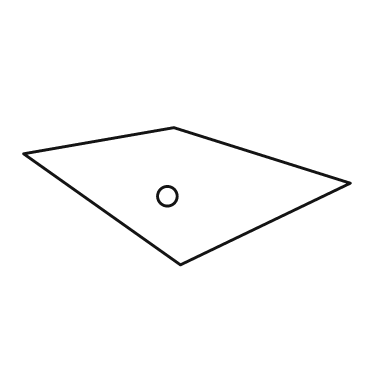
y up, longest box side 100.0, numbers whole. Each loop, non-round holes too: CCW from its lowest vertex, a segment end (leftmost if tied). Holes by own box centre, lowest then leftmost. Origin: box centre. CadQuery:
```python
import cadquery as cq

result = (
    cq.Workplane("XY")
    .moveTo(-2.0, -21.0)
    .lineTo(50.0, 4.0)
    .lineTo(-4.0, 21.0)
    .lineTo(-50.0, 13.0)
    .close()
    .moveTo(-6.0, 0.0)
    .circle(3.0)
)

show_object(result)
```